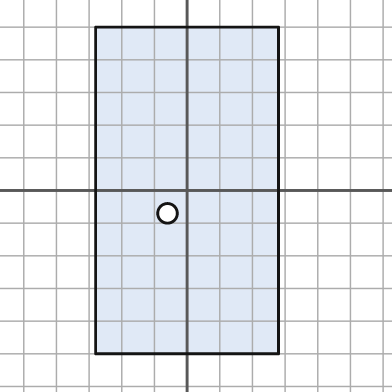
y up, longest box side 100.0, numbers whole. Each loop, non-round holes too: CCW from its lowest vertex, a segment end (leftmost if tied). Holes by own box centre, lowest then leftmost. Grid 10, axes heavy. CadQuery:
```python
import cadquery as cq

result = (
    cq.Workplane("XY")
    .moveTo(-28.0, -50.0)
    .lineTo(28.0, -50.0)
    .lineTo(28.0, 50.0)
    .lineTo(-28.0, 50.0)
    .close()
    .moveTo(-6.0, -7.0)
    .circle(3.0)
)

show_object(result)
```